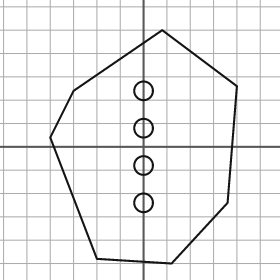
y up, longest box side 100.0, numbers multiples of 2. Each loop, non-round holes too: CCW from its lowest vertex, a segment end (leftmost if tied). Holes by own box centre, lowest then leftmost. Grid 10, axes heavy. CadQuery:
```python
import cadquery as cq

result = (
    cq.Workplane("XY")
    .moveTo(12.0, -50.0)
    .lineTo(36.0, -24.0)
    .lineTo(40.0, 26.0)
    .lineTo(8.0, 50.0)
    .lineTo(-30.0, 24.0)
    .lineTo(-40.0, 4.0)
    .lineTo(-20.0, -48.0)
    .close()
    .moveTo(0.0, -24.0)
    .circle(4.0)
    .moveTo(0.0, -8.0)
    .circle(4.0)
    .moveTo(0.0, 8.0)
    .circle(4.0)
    .moveTo(0.0, 24.0)
    .circle(4.0)
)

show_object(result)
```